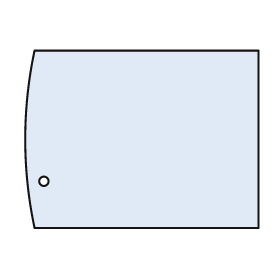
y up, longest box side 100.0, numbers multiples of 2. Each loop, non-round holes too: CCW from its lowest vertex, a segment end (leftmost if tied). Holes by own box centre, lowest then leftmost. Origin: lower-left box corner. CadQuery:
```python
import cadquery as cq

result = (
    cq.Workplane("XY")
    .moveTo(4.0, 0.0)
    .lineTo(100.0, 0.0)
    .lineTo(100.0, 76.0)
    .lineTo(4.0, 76.0)
    .threePointArc((0.0, 38.0), (4.0, 0.0))
    .close()
    .moveTo(8.0, 20.0)
    .circle(2.0)
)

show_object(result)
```